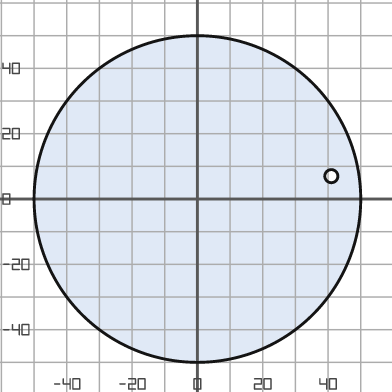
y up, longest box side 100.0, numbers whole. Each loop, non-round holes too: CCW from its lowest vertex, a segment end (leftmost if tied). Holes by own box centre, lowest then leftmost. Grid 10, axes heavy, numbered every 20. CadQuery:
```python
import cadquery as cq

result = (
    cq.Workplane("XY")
    .moveTo(0.0, 0.0)
    .circle(50.0)
    .moveTo(41.0, 7.0)
    .circle(2.0)
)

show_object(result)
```